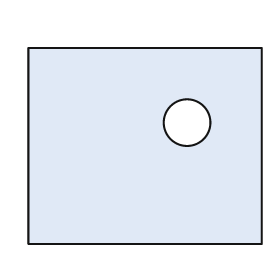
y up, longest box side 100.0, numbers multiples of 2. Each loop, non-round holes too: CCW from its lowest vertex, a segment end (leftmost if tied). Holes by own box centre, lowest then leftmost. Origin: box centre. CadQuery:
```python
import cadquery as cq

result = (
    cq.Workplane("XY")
    .moveTo(-50.0, -42.0)
    .lineTo(50.0, -42.0)
    .lineTo(50.0, 42.0)
    .lineTo(-50.0, 42.0)
    .close()
    .moveTo(18.0, 10.0)
    .circle(10.0)
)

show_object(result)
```